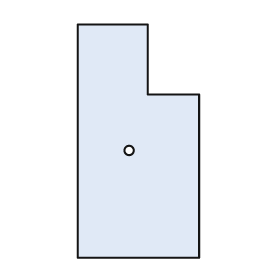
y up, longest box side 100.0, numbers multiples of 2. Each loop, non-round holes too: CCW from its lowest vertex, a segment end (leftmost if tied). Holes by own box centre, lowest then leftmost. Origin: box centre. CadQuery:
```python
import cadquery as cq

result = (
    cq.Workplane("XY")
    .moveTo(-26.0, -50.0)
    .lineTo(26.0, -50.0)
    .lineTo(26.0, 20.0)
    .lineTo(4.0, 20.0)
    .lineTo(4.0, 50.0)
    .lineTo(-26.0, 50.0)
    .close()
    .moveTo(-4.0, -4.0)
    .circle(2.0)
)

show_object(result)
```